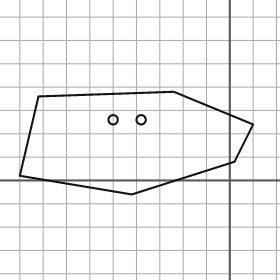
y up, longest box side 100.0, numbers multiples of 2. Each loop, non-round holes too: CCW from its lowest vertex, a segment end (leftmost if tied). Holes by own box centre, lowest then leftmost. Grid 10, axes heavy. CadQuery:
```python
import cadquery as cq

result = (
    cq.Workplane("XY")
    .moveTo(-42.0, -6.0)
    .lineTo(2.0, 8.0)
    .lineTo(10.0, 24.0)
    .lineTo(-24.0, 38.0)
    .lineTo(-82.0, 36.0)
    .lineTo(-90.0, 2.0)
    .close()
    .moveTo(-50.0, 26.0)
    .circle(2.0)
    .moveTo(-38.0, 26.0)
    .circle(2.0)
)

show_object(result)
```